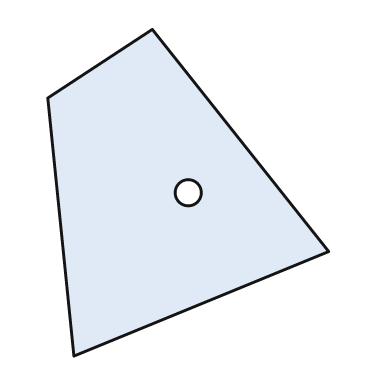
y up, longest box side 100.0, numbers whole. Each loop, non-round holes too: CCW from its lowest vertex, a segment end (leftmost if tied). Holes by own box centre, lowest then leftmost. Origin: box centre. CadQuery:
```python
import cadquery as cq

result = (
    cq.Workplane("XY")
    .moveTo(-35.0, -50.0)
    .lineTo(43.0, -18.0)
    .lineTo(-11.0, 50.0)
    .lineTo(-43.0, 29.0)
    .close()
    .moveTo(0.0, 0.0)
    .circle(4.0)
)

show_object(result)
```